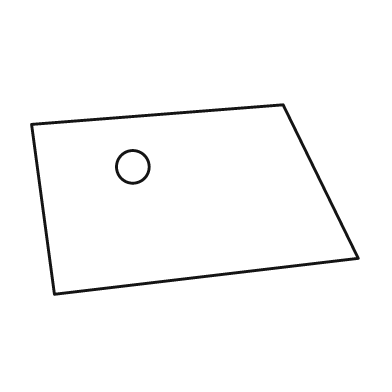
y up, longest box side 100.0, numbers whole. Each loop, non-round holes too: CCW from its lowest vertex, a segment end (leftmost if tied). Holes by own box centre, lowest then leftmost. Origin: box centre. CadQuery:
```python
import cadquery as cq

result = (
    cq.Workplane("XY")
    .moveTo(-43.0, -29.0)
    .lineTo(50.0, -18.0)
    .lineTo(27.0, 29.0)
    .lineTo(-50.0, 23.0)
    .close()
    .moveTo(-19.0, 10.0)
    .circle(5.0)
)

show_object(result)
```